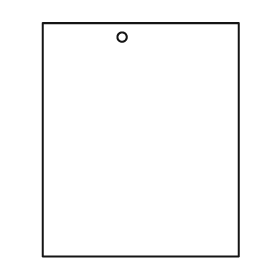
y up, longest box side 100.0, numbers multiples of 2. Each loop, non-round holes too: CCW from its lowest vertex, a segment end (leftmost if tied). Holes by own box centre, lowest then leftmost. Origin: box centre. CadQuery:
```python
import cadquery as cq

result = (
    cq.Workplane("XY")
    .moveTo(-42.0, -50.0)
    .lineTo(42.0, -50.0)
    .lineTo(42.0, 50.0)
    .lineTo(-42.0, 50.0)
    .close()
    .moveTo(-8.0, 44.0)
    .circle(2.0)
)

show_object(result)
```